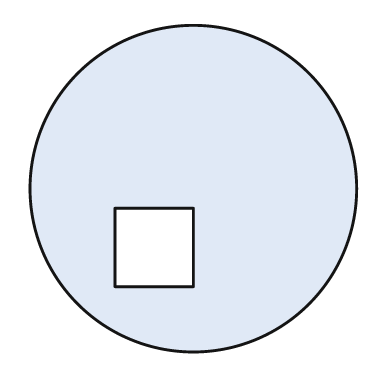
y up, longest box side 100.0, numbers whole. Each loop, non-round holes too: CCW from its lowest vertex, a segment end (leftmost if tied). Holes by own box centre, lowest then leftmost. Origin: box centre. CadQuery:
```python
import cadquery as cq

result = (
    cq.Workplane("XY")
    .moveTo(0.0, 0.0)
    .circle(50.0)
    .moveTo(-24.0, -30.0)
    .lineTo(0.0, -30.0)
    .lineTo(0.0, -6.0)
    .lineTo(-24.0, -6.0)
    .close()
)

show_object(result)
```